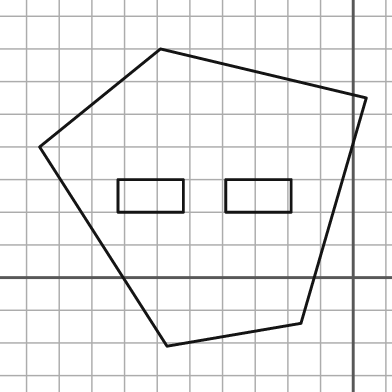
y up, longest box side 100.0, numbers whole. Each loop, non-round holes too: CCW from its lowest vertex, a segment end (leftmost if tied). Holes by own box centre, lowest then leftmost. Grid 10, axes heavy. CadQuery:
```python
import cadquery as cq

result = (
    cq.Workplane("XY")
    .moveTo(-57.0, -21.0)
    .lineTo(-16.0, -14.0)
    .lineTo(4.0, 55.0)
    .lineTo(-59.0, 70.0)
    .lineTo(-96.0, 40.0)
    .close()
    .moveTo(-72.0, 20.0)
    .lineTo(-52.0, 20.0)
    .lineTo(-52.0, 30.0)
    .lineTo(-72.0, 30.0)
    .close()
    .moveTo(-39.0, 20.0)
    .lineTo(-19.0, 20.0)
    .lineTo(-19.0, 30.0)
    .lineTo(-39.0, 30.0)
    .close()
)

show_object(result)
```